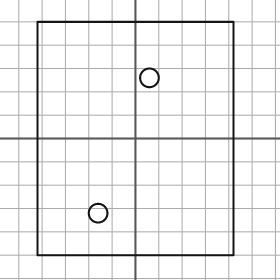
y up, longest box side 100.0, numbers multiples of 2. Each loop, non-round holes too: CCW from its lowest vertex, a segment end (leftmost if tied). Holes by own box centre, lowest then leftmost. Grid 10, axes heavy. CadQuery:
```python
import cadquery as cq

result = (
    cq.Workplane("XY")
    .moveTo(-42.0, -50.0)
    .lineTo(42.0, -50.0)
    .lineTo(42.0, 50.0)
    .lineTo(-42.0, 50.0)
    .close()
    .moveTo(-16.0, -32.0)
    .circle(4.0)
    .moveTo(6.0, 26.0)
    .circle(4.0)
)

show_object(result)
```